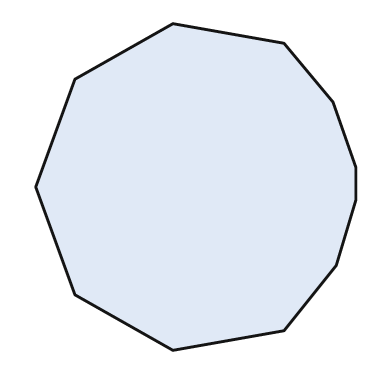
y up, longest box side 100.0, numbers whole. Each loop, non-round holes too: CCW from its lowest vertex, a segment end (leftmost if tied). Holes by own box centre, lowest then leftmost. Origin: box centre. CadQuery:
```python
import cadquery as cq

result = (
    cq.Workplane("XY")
    .moveTo(-7.0, -50.0)
    .lineTo(27.0, -44.0)
    .lineTo(43.0, -24.0)
    .lineTo(49.0, -4.0)
    .lineTo(49.0, 6.0)
    .lineTo(42.0, 26.0)
    .lineTo(27.0, 44.0)
    .lineTo(-7.0, 50.0)
    .lineTo(-37.0, 33.0)
    .lineTo(-49.0, 0.0)
    .lineTo(-37.0, -33.0)
    .close()
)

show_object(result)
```